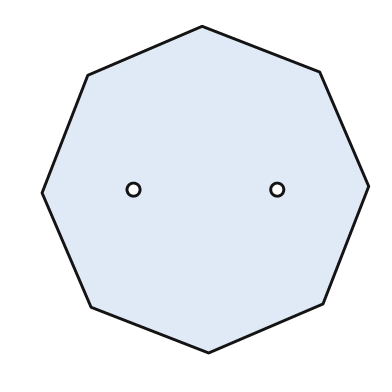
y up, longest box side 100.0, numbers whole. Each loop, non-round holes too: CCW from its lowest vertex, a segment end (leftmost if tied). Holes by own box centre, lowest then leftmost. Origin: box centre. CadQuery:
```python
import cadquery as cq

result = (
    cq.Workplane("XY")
    .moveTo(1.0, -50.0)
    .lineTo(36.0, -35.0)
    .lineTo(50.0, 1.0)
    .lineTo(35.0, 36.0)
    .lineTo(-1.0, 50.0)
    .lineTo(-36.0, 35.0)
    .lineTo(-50.0, -1.0)
    .lineTo(-35.0, -36.0)
    .close()
    .moveTo(-22.0, 0.0)
    .circle(2.0)
    .moveTo(22.0, 0.0)
    .circle(2.0)
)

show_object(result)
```